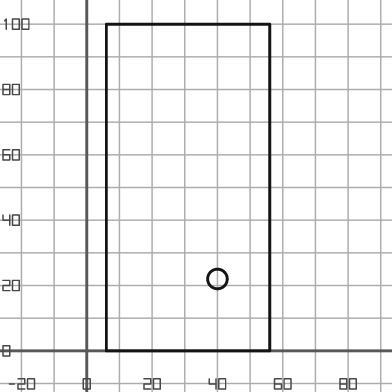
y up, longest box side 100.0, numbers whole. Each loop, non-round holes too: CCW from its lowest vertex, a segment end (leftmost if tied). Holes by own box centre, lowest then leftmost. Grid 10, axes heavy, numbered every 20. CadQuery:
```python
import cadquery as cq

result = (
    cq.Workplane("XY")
    .moveTo(6.0, 0.0)
    .lineTo(56.0, 0.0)
    .lineTo(56.0, 100.0)
    .lineTo(6.0, 100.0)
    .close()
    .moveTo(40.0, 22.0)
    .circle(3.0)
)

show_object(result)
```